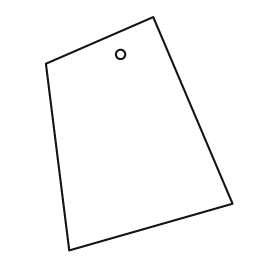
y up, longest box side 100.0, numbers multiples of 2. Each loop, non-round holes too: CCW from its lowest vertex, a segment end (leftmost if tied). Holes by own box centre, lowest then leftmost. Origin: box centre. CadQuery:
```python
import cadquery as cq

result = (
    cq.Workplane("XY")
    .moveTo(-30.0, -50.0)
    .lineTo(40.0, -30.0)
    .lineTo(6.0, 50.0)
    .lineTo(-40.0, 30.0)
    .close()
    .moveTo(-8.0, 34.0)
    .circle(2.0)
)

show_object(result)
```